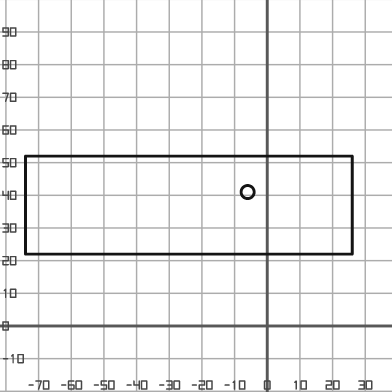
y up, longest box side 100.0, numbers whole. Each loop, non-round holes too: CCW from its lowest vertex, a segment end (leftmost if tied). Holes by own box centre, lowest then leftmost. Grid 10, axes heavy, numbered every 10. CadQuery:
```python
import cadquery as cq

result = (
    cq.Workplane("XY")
    .moveTo(-74.0, 22.0)
    .lineTo(26.0, 22.0)
    .lineTo(26.0, 52.0)
    .lineTo(-74.0, 52.0)
    .close()
    .moveTo(-6.0, 41.0)
    .circle(2.0)
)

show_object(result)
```